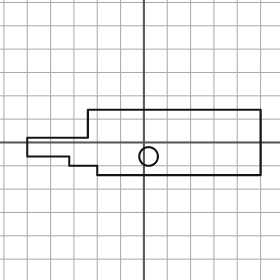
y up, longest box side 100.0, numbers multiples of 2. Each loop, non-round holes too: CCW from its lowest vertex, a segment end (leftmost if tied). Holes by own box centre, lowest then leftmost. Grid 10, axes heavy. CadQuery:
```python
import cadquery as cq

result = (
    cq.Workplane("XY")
    .moveTo(-20.0, -14.0)
    .lineTo(50.0, -14.0)
    .lineTo(50.0, 14.0)
    .lineTo(-24.0, 14.0)
    .lineTo(-24.0, 2.0)
    .lineTo(-50.0, 2.0)
    .lineTo(-50.0, -6.0)
    .lineTo(-32.0, -6.0)
    .lineTo(-32.0, -10.0)
    .lineTo(-20.0, -10.0)
    .close()
    .moveTo(2.0, -6.0)
    .circle(4.0)
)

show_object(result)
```